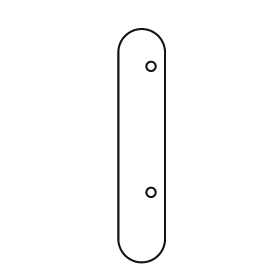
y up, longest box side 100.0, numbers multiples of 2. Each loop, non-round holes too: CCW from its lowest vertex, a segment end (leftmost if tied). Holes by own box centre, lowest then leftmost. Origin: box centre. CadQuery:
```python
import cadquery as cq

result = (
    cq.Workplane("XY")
    .moveTo(-10.0, -40.0)
    .threePointArc((0.0, -50.0), (10.0, -40.0))
    .lineTo(10.0, 40.0)
    .threePointArc((0.0, 50.0), (-10.0, 40.0))
    .close()
    .moveTo(4.0, -20.0)
    .circle(2.0)
    .moveTo(4.0, 34.0)
    .circle(2.0)
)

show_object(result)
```